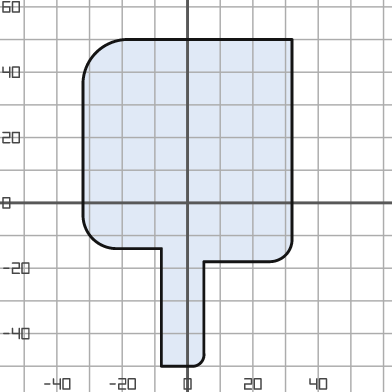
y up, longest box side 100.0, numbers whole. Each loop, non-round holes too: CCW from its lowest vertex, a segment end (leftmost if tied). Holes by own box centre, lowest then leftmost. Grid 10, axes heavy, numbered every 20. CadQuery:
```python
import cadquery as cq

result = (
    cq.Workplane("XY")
    .moveTo(-8.0, -50.0)
    .lineTo(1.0, -50.0)
    .threePointArc((4.0, -49.0), (5.0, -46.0))
    .lineTo(5.0, -18.0)
    .lineTo(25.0, -18.0)
    .threePointArc((30.0, -16.0), (32.0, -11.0))
    .lineTo(32.0, 50.0)
    .lineTo(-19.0, 50.0)
    .threePointArc((-28.0, 46.0), (-32.0, 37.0))
    .lineTo(-32.0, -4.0)
    .threePointArc((-29.0, -11.0), (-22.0, -14.0))
    .lineTo(-8.0, -14.0)
    .close()
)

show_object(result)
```